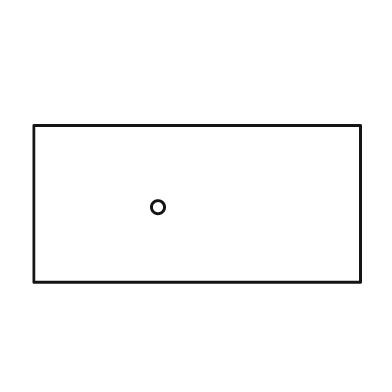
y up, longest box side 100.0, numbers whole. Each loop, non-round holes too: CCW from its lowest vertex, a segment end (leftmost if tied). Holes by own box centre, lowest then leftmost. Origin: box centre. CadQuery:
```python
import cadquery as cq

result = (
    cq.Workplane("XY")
    .moveTo(-50.0, -24.0)
    .lineTo(50.0, -24.0)
    .lineTo(50.0, 24.0)
    .lineTo(-50.0, 24.0)
    .close()
    .moveTo(-12.0, -1.0)
    .circle(2.0)
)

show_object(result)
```